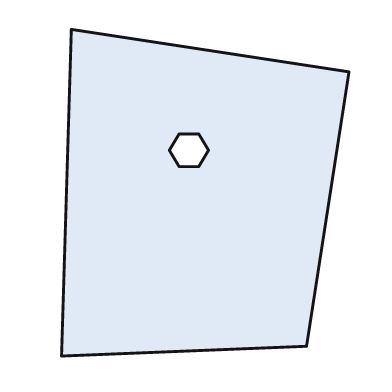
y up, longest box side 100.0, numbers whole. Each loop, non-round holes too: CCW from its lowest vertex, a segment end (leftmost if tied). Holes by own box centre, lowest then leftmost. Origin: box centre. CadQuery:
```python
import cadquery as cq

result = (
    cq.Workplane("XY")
    .moveTo(-44.0, -50.0)
    .lineTo(31.0, -47.0)
    .lineTo(44.0, 37.0)
    .lineTo(-41.0, 50.0)
    .close()
    .moveTo(-8.0, 8.0)
    .lineTo(-2.0, 8.0)
    .lineTo(1.0, 13.0)
    .lineTo(-2.0, 18.0)
    .lineTo(-8.0, 18.0)
    .lineTo(-11.0, 13.0)
    .close()
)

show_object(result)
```